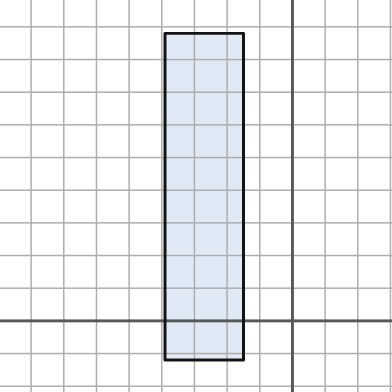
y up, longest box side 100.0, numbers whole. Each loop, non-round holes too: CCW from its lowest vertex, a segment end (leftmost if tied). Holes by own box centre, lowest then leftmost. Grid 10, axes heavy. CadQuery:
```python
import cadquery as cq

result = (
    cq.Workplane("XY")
    .moveTo(-39.0, -12.0)
    .lineTo(-15.0, -12.0)
    .lineTo(-15.0, 88.0)
    .lineTo(-39.0, 88.0)
    .close()
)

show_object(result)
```